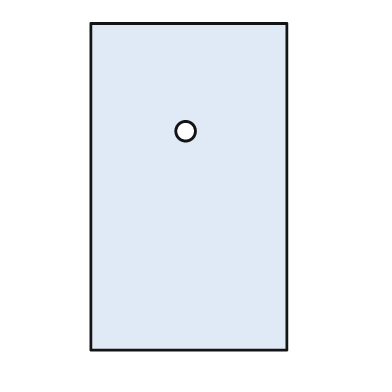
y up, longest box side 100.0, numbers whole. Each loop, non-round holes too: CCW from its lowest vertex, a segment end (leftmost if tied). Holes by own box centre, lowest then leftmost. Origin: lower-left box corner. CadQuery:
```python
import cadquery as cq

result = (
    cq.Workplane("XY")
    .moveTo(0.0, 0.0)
    .lineTo(60.0, 0.0)
    .lineTo(60.0, 100.0)
    .lineTo(0.0, 100.0)
    .close()
    .moveTo(29.0, 67.0)
    .circle(3.0)
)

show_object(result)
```